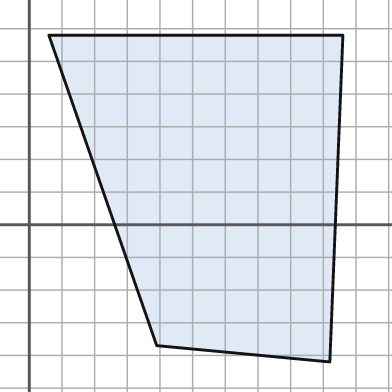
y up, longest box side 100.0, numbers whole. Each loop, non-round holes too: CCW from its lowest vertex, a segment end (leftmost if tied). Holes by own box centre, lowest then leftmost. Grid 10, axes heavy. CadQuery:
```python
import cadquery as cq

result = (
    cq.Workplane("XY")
    .moveTo(92.0, -42.0)
    .lineTo(96.0, 58.0)
    .lineTo(6.0, 58.0)
    .lineTo(39.0, -37.0)
    .close()
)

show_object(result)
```